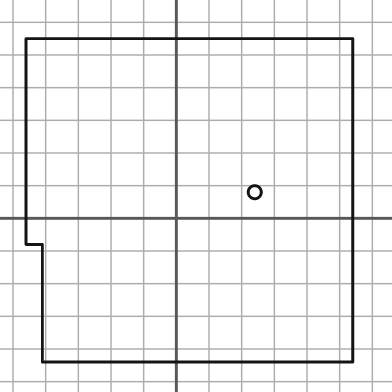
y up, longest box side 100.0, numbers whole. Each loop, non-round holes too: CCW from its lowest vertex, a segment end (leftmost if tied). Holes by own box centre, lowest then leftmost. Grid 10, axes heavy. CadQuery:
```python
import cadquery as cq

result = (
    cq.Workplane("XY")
    .moveTo(-41.0, -44.0)
    .lineTo(54.0, -44.0)
    .lineTo(54.0, 55.0)
    .lineTo(-46.0, 55.0)
    .lineTo(-46.0, -8.0)
    .lineTo(-41.0, -8.0)
    .close()
    .moveTo(24.0, 8.0)
    .circle(2.0)
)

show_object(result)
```